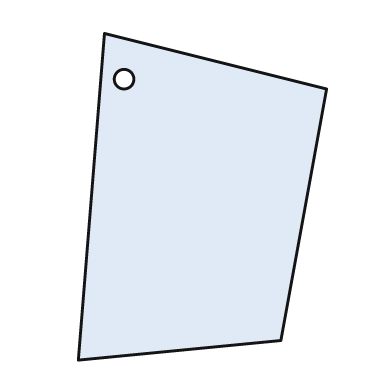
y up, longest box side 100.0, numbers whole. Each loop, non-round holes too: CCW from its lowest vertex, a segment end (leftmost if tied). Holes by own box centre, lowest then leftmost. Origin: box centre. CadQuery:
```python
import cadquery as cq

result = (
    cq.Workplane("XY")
    .moveTo(-38.0, -50.0)
    .lineTo(24.0, -44.0)
    .lineTo(38.0, 33.0)
    .lineTo(-30.0, 50.0)
    .close()
    .moveTo(-24.0, 36.0)
    .circle(3.0)
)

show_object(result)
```